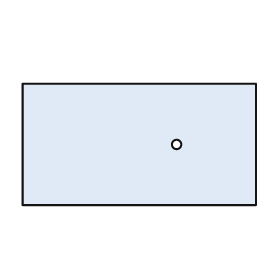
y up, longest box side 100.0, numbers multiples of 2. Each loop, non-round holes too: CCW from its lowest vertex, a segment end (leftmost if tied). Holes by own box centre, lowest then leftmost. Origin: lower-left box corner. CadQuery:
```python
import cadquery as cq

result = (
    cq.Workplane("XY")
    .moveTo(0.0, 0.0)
    .lineTo(100.0, 0.0)
    .lineTo(100.0, 52.0)
    .lineTo(0.0, 52.0)
    .close()
    .moveTo(66.0, 26.0)
    .circle(2.0)
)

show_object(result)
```